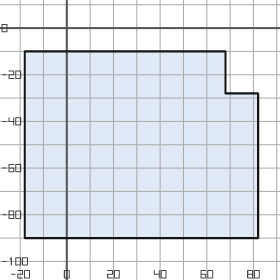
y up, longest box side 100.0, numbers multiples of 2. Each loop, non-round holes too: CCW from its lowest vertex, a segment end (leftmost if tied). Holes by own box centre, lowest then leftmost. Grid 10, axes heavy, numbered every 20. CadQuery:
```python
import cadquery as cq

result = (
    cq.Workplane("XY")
    .moveTo(-18.0, -90.0)
    .lineTo(82.0, -90.0)
    .lineTo(82.0, -28.0)
    .lineTo(68.0, -28.0)
    .lineTo(68.0, -10.0)
    .lineTo(-18.0, -10.0)
    .close()
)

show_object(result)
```